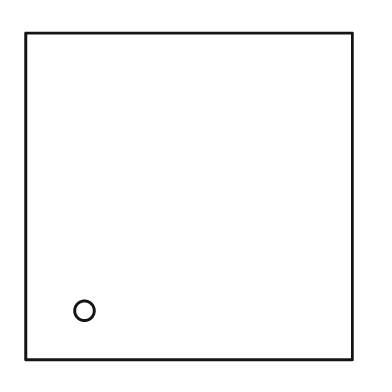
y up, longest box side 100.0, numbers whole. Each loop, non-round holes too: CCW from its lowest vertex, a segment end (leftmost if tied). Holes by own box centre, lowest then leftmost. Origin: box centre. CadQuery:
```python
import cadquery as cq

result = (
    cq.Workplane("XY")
    .moveTo(-50.0, -50.0)
    .lineTo(50.0, -50.0)
    .lineTo(50.0, 50.0)
    .lineTo(-50.0, 50.0)
    .close()
    .moveTo(-32.0, -35.0)
    .circle(3.0)
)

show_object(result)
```